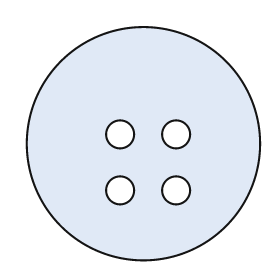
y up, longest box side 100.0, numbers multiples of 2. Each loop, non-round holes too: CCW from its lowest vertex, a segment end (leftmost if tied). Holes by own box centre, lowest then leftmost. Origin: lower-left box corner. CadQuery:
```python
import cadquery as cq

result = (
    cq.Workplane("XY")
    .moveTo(50.0, 50.0)
    .circle(50.0)
    .moveTo(40.0, 30.0)
    .circle(6.0)
    .moveTo(64.0, 30.0)
    .circle(6.0)
    .moveTo(40.0, 54.0)
    .circle(6.0)
    .moveTo(64.0, 54.0)
    .circle(6.0)
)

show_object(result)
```